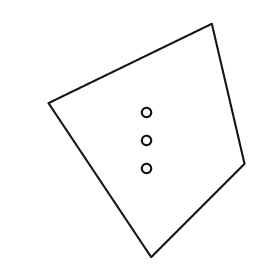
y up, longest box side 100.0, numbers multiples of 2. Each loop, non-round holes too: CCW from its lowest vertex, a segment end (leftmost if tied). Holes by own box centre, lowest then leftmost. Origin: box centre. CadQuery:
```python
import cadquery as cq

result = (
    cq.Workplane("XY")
    .moveTo(2.0, -50.0)
    .lineTo(42.0, -10.0)
    .lineTo(28.0, 50.0)
    .lineTo(-42.0, 16.0)
    .close()
    .moveTo(0.0, -12.0)
    .circle(2.0)
    .moveTo(0.0, 0.0)
    .circle(2.0)
    .moveTo(0.0, 12.0)
    .circle(2.0)
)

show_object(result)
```